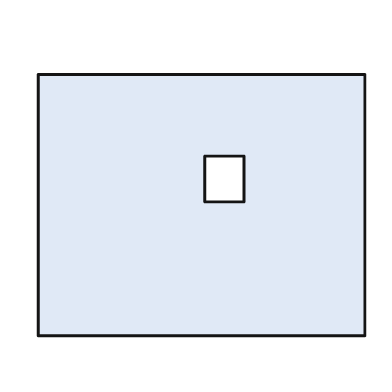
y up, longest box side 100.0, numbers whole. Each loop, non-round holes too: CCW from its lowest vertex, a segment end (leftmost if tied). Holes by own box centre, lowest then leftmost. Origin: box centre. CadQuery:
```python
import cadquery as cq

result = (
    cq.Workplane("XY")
    .moveTo(-50.0, -40.0)
    .lineTo(50.0, -40.0)
    .lineTo(50.0, 40.0)
    .lineTo(-50.0, 40.0)
    .close()
    .moveTo(1.0, 1.0)
    .lineTo(13.0, 1.0)
    .lineTo(13.0, 15.0)
    .lineTo(1.0, 15.0)
    .close()
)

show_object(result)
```